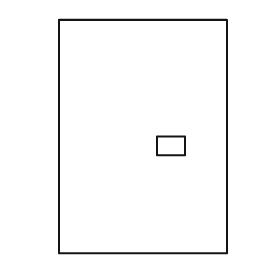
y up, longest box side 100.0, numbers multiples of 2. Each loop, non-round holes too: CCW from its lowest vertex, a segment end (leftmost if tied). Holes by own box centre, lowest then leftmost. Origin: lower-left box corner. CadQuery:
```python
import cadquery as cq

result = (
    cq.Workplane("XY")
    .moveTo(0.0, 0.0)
    .lineTo(72.0, 0.0)
    .lineTo(72.0, 100.0)
    .lineTo(0.0, 100.0)
    .close()
    .moveTo(42.0, 42.0)
    .lineTo(54.0, 42.0)
    .lineTo(54.0, 50.0)
    .lineTo(42.0, 50.0)
    .close()
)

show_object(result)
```